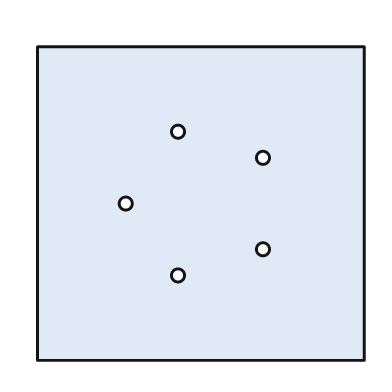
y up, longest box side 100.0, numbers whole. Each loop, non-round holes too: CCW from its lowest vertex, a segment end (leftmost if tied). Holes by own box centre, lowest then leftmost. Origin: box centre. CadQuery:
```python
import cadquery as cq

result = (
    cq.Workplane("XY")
    .moveTo(-50.0, -48.0)
    .lineTo(50.0, -48.0)
    .lineTo(50.0, 48.0)
    .lineTo(-50.0, 48.0)
    .close()
    .moveTo(-7.0, -22.0)
    .circle(2.0)
    .moveTo(19.0, -14.0)
    .circle(2.0)
    .moveTo(-23.0, 0.0)
    .circle(2.0)
    .moveTo(19.0, 14.0)
    .circle(2.0)
    .moveTo(-7.0, 22.0)
    .circle(2.0)
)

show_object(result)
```